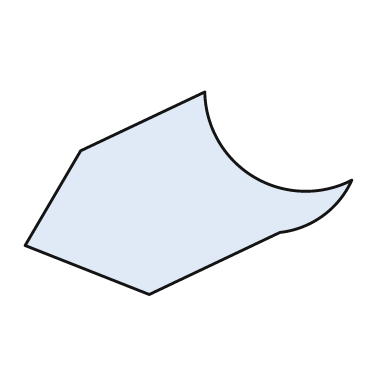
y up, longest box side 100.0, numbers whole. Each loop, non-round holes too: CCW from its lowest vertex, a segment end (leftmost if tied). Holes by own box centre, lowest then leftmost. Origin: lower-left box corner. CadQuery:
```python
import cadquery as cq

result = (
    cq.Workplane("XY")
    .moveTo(38.0, 0.0)
    .lineTo(78.0, 19.0)
    .threePointArc((91.0, 24.0), (100.0, 35.0))
    .threePointArc((70.0, 36.0), (55.0, 62.0))
    .lineTo(17.0, 44.0)
    .lineTo(0.0, 15.0)
    .close()
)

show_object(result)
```